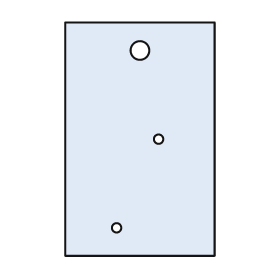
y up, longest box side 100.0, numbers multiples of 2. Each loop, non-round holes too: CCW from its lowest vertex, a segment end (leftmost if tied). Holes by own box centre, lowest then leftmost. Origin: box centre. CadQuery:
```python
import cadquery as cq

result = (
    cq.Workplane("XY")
    .moveTo(-32.0, -50.0)
    .lineTo(32.0, -50.0)
    .lineTo(32.0, 50.0)
    .lineTo(-32.0, 50.0)
    .close()
    .moveTo(-10.0, -38.0)
    .circle(2.0)
    .moveTo(8.0, 0.0)
    .circle(2.0)
    .moveTo(0.0, 38.0)
    .circle(4.0)
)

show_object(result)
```